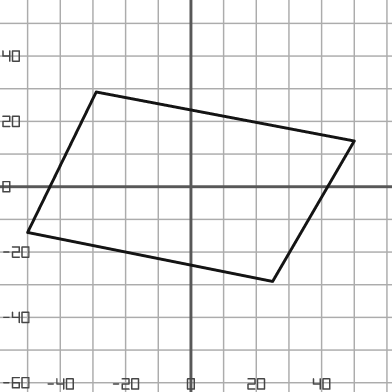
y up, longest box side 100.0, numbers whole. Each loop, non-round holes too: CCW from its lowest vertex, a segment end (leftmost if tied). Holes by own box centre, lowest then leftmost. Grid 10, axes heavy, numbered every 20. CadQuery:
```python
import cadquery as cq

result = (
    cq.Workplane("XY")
    .moveTo(25.0, -29.0)
    .lineTo(50.0, 14.0)
    .lineTo(-29.0, 29.0)
    .lineTo(-50.0, -14.0)
    .close()
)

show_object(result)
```